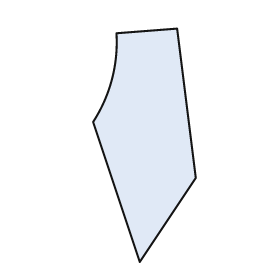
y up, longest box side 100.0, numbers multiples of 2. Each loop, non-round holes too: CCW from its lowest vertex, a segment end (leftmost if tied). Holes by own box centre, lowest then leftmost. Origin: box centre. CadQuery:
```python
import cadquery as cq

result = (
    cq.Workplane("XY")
    .moveTo(-2.0, -50.0)
    .lineTo(22.0, -14.0)
    .lineTo(14.0, 50.0)
    .lineTo(-12.0, 48.0)
    .threePointArc((-14.0, 28.0), (-22.0, 10.0))
    .close()
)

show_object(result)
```